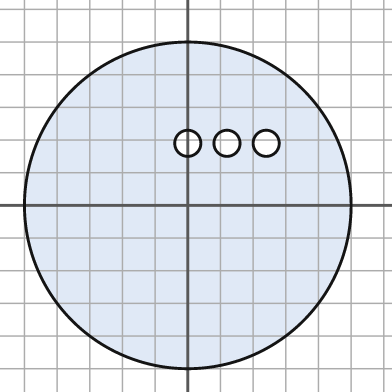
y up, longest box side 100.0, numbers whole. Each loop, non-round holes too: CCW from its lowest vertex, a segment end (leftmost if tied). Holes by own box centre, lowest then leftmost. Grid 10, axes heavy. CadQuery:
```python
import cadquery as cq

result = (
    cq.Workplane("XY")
    .moveTo(0.0, 0.0)
    .circle(50.0)
    .moveTo(0.0, 19.0)
    .circle(4.0)
    .moveTo(12.0, 19.0)
    .circle(4.0)
    .moveTo(24.0, 19.0)
    .circle(4.0)
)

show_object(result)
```